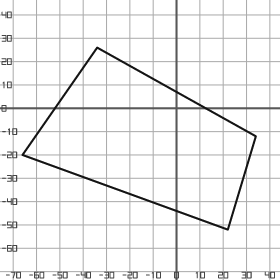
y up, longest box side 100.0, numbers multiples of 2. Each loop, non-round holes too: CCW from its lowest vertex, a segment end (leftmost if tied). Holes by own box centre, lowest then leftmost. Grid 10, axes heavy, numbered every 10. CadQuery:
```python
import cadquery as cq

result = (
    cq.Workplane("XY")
    .moveTo(22.0, -52.0)
    .lineTo(34.0, -12.0)
    .lineTo(-34.0, 26.0)
    .lineTo(-66.0, -20.0)
    .close()
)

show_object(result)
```